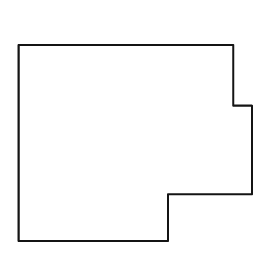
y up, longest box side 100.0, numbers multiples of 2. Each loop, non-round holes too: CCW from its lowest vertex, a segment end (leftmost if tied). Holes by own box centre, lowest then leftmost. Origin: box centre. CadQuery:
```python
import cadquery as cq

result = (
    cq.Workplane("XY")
    .moveTo(-50.0, -42.0)
    .lineTo(14.0, -42.0)
    .lineTo(14.0, -22.0)
    .lineTo(50.0, -22.0)
    .lineTo(50.0, 16.0)
    .lineTo(42.0, 16.0)
    .lineTo(42.0, 42.0)
    .lineTo(-50.0, 42.0)
    .close()
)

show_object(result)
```